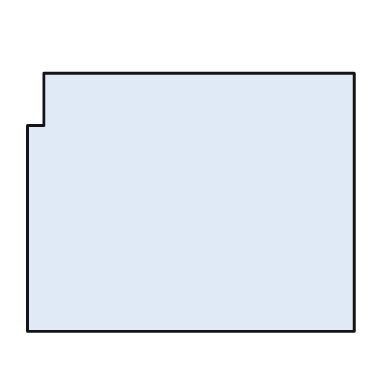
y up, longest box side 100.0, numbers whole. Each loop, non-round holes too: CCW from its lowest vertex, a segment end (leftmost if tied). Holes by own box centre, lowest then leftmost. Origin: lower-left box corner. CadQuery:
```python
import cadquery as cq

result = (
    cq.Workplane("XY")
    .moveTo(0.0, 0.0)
    .lineTo(100.0, 0.0)
    .lineTo(100.0, 79.0)
    .lineTo(5.0, 79.0)
    .lineTo(5.0, 63.0)
    .lineTo(0.0, 63.0)
    .close()
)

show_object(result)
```